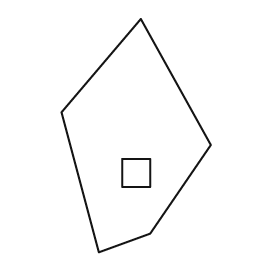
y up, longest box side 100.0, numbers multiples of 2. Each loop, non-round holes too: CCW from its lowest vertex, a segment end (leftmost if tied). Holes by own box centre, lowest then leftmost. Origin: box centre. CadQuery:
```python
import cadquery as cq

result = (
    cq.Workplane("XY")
    .moveTo(-16.0, -50.0)
    .lineTo(6.0, -42.0)
    .lineTo(32.0, -4.0)
    .lineTo(2.0, 50.0)
    .lineTo(-32.0, 10.0)
    .close()
    .moveTo(-6.0, -22.0)
    .lineTo(6.0, -22.0)
    .lineTo(6.0, -10.0)
    .lineTo(-6.0, -10.0)
    .close()
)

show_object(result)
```